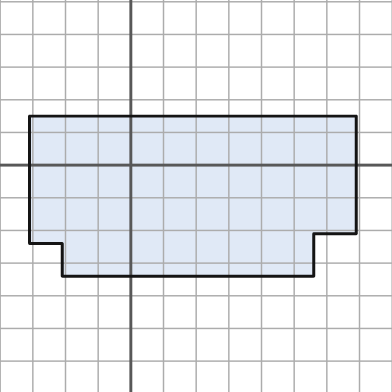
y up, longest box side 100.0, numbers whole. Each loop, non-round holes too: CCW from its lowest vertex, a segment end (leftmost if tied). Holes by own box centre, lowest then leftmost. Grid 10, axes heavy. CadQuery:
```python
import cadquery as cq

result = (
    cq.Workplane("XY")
    .moveTo(-21.0, -34.0)
    .lineTo(56.0, -34.0)
    .lineTo(56.0, -21.0)
    .lineTo(69.0, -21.0)
    .lineTo(69.0, 15.0)
    .lineTo(-31.0, 15.0)
    .lineTo(-31.0, -24.0)
    .lineTo(-21.0, -24.0)
    .close()
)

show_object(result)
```